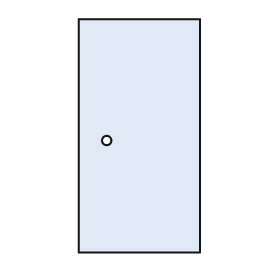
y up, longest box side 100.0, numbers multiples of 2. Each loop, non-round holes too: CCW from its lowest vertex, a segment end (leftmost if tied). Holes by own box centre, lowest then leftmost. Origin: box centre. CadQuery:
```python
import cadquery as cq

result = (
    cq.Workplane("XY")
    .moveTo(-26.0, -50.0)
    .lineTo(26.0, -50.0)
    .lineTo(26.0, 50.0)
    .lineTo(-26.0, 50.0)
    .close()
    .moveTo(-14.0, -2.0)
    .circle(2.0)
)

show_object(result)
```